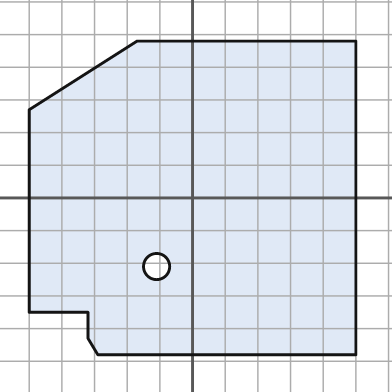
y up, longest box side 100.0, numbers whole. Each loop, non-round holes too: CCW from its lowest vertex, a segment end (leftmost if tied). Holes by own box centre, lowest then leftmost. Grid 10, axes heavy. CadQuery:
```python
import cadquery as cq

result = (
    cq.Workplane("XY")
    .moveTo(-29.0, -48.0)
    .lineTo(50.0, -48.0)
    .lineTo(50.0, 48.0)
    .lineTo(-17.0, 48.0)
    .lineTo(-50.0, 27.0)
    .lineTo(-50.0, -35.0)
    .lineTo(-32.0, -35.0)
    .lineTo(-32.0, -43.0)
    .close()
    .moveTo(-11.0, -21.0)
    .circle(4.0)
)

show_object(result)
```